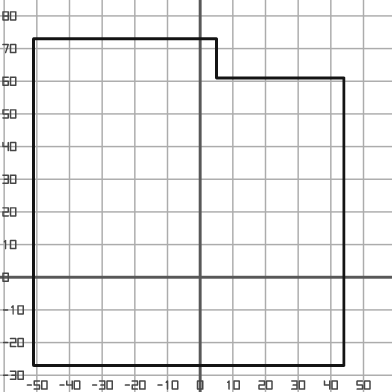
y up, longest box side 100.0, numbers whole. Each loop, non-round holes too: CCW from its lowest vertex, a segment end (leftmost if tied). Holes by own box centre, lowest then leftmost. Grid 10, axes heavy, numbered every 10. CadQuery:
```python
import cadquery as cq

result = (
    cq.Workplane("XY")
    .moveTo(-51.0, -27.0)
    .lineTo(44.0, -27.0)
    .lineTo(44.0, 61.0)
    .lineTo(5.0, 61.0)
    .lineTo(5.0, 73.0)
    .lineTo(-51.0, 73.0)
    .close()
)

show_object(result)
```